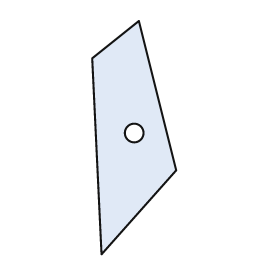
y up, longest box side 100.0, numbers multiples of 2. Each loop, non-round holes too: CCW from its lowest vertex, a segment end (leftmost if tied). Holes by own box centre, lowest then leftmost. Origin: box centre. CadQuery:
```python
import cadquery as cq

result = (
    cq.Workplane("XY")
    .moveTo(-14.0, -50.0)
    .lineTo(18.0, -14.0)
    .lineTo(2.0, 50.0)
    .lineTo(-18.0, 34.0)
    .close()
    .moveTo(0.0, 2.0)
    .circle(4.0)
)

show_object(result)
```